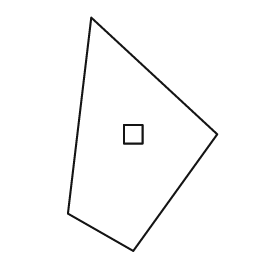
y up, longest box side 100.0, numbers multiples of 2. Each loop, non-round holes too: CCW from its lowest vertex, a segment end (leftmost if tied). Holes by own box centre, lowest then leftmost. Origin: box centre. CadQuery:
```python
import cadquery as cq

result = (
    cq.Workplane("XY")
    .moveTo(-4.0, -50.0)
    .lineTo(32.0, 0.0)
    .lineTo(-22.0, 50.0)
    .lineTo(-32.0, -34.0)
    .close()
    .moveTo(-8.0, -4.0)
    .lineTo(0.0, -4.0)
    .lineTo(0.0, 4.0)
    .lineTo(-8.0, 4.0)
    .close()
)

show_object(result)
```